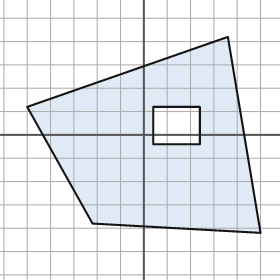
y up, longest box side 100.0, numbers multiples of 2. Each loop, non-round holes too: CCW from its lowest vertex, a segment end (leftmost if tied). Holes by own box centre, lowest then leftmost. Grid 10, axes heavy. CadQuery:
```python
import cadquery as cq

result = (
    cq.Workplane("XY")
    .moveTo(50.0, -42.0)
    .lineTo(36.0, 42.0)
    .lineTo(-50.0, 12.0)
    .lineTo(-22.0, -38.0)
    .close()
    .moveTo(4.0, -4.0)
    .lineTo(24.0, -4.0)
    .lineTo(24.0, 12.0)
    .lineTo(4.0, 12.0)
    .close()
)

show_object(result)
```